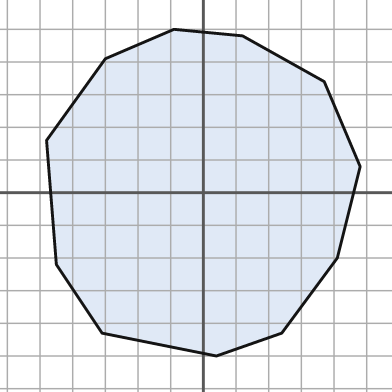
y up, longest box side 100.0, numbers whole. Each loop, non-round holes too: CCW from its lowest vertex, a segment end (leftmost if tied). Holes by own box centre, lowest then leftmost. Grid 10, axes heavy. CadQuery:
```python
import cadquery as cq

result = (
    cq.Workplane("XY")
    .moveTo(4.0, -50.0)
    .lineTo(24.0, -43.0)
    .lineTo(41.0, -20.0)
    .lineTo(48.0, 8.0)
    .lineTo(37.0, 34.0)
    .lineTo(12.0, 48.0)
    .lineTo(-9.0, 50.0)
    .lineTo(-30.0, 41.0)
    .lineTo(-48.0, 16.0)
    .lineTo(-45.0, -22.0)
    .lineTo(-31.0, -43.0)
    .close()
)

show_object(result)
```